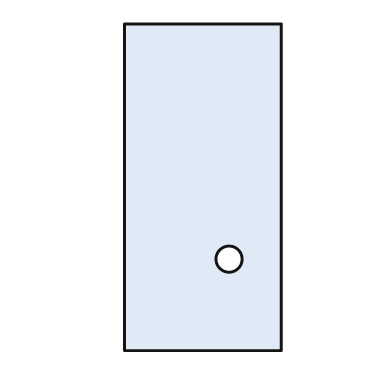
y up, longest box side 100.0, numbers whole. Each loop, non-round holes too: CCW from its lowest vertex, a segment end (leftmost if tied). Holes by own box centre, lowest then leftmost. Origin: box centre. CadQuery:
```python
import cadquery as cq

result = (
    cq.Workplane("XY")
    .moveTo(-24.0, -50.0)
    .lineTo(24.0, -50.0)
    .lineTo(24.0, 50.0)
    .lineTo(-24.0, 50.0)
    .close()
    .moveTo(8.0, -22.0)
    .circle(4.0)
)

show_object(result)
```